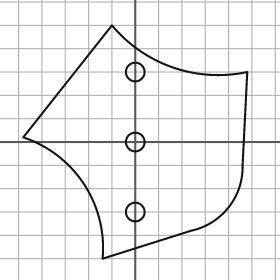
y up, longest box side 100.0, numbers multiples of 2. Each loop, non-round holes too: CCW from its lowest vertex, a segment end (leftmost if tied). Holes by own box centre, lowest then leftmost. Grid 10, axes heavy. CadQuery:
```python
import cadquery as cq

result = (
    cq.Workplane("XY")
    .moveTo(-14.0, -50.0)
    .lineTo(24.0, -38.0)
    .threePointArc((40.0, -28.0), (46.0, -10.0))
    .lineTo(48.0, 30.0)
    .threePointArc((16.0, 32.0), (-10.0, 50.0))
    .lineTo(-48.0, 2.0)
    .threePointArc((-22.0, -18.0), (-14.0, -50.0))
    .close()
    .moveTo(0.0, -30.0)
    .circle(4.0)
    .moveTo(0.0, 0.0)
    .circle(4.0)
    .moveTo(0.0, 30.0)
    .circle(4.0)
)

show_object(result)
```